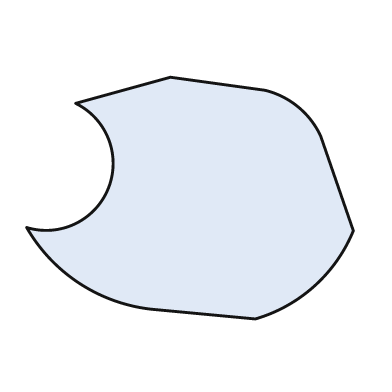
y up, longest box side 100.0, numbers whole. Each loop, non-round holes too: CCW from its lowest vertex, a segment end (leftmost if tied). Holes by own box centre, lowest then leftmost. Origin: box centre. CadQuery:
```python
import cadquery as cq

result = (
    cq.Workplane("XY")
    .moveTo(20.0, -37.0)
    .threePointArc((38.0, -27.0), (50.0, -10.0))
    .lineTo(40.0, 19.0)
    .threePointArc((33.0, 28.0), (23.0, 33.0))
    .lineTo(-6.0, 37.0)
    .lineTo(-35.0, 29.0)
    .threePointArc((-25.0, 3.0), (-50.0, -9.0))
    .threePointArc((-34.0, -26.0), (-12.0, -34.0))
    .close()
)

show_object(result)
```